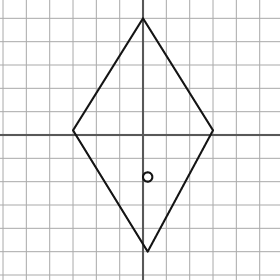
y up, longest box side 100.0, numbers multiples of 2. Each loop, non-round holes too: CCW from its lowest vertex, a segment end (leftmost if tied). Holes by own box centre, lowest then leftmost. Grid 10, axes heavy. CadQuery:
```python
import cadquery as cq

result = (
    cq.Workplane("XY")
    .moveTo(2.0, -50.0)
    .lineTo(30.0, 2.0)
    .lineTo(0.0, 50.0)
    .lineTo(-30.0, 2.0)
    .close()
    .moveTo(2.0, -18.0)
    .circle(2.0)
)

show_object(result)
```